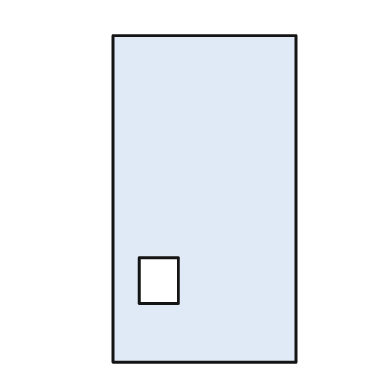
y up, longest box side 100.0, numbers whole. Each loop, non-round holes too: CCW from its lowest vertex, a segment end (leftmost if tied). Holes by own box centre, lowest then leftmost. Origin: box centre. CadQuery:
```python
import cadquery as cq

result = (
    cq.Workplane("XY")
    .moveTo(-28.0, -50.0)
    .lineTo(28.0, -50.0)
    .lineTo(28.0, 50.0)
    .lineTo(-28.0, 50.0)
    .close()
    .moveTo(-20.0, -32.0)
    .lineTo(-8.0, -32.0)
    .lineTo(-8.0, -18.0)
    .lineTo(-20.0, -18.0)
    .close()
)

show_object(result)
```